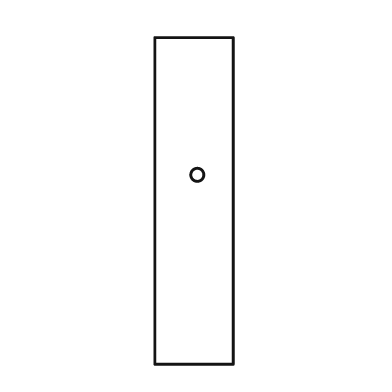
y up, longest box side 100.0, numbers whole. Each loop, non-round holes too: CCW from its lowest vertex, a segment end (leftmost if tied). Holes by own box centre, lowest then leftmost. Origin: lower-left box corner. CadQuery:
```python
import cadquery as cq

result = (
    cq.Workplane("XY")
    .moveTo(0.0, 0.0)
    .lineTo(24.0, 0.0)
    .lineTo(24.0, 100.0)
    .lineTo(0.0, 100.0)
    .close()
    .moveTo(13.0, 58.0)
    .circle(2.0)
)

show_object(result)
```